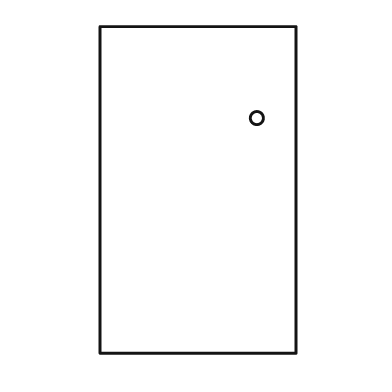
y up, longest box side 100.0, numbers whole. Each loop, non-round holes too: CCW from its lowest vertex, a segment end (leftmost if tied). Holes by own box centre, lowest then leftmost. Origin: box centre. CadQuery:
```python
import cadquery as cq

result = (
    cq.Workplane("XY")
    .moveTo(-30.0, -50.0)
    .lineTo(30.0, -50.0)
    .lineTo(30.0, 50.0)
    .lineTo(-30.0, 50.0)
    .close()
    .moveTo(18.0, 22.0)
    .circle(2.0)
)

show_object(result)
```